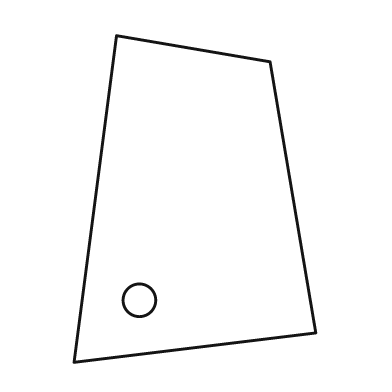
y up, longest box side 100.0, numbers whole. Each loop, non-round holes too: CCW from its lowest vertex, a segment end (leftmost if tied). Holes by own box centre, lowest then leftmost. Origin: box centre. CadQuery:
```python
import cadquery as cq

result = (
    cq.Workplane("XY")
    .moveTo(-37.0, -50.0)
    .lineTo(37.0, -41.0)
    .lineTo(23.0, 42.0)
    .lineTo(-24.0, 50.0)
    .close()
    .moveTo(-17.0, -31.0)
    .circle(5.0)
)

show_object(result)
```